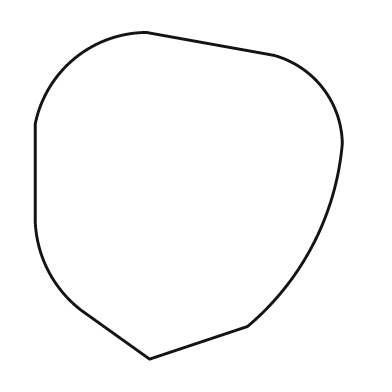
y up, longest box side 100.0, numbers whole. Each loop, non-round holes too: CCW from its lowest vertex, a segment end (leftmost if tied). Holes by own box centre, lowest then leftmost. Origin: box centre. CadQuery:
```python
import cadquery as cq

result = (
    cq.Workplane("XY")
    .moveTo(-12.0, -50.0)
    .lineTo(18.0, -40.0)
    .threePointArc((38.0, -15.0), (47.0, 16.0))
    .threePointArc((41.0, 33.0), (26.0, 43.0))
    .lineTo(-13.0, 50.0)
    .threePointArc((-35.0, 42.0), (-47.0, 22.0))
    .lineTo(-47.0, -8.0)
    .threePointArc((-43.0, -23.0), (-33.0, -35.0))
    .close()
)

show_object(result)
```